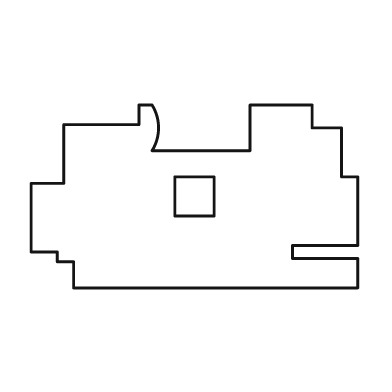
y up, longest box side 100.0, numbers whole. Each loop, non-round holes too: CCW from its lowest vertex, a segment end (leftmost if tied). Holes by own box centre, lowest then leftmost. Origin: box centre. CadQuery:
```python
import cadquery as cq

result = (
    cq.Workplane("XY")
    .moveTo(-37.0, -28.0)
    .lineTo(50.0, -28.0)
    .lineTo(50.0, -19.0)
    .lineTo(30.0, -19.0)
    .lineTo(30.0, -15.0)
    .lineTo(50.0, -15.0)
    .lineTo(50.0, 6.0)
    .lineTo(45.0, 6.0)
    .lineTo(45.0, 21.0)
    .lineTo(36.0, 21.0)
    .lineTo(36.0, 28.0)
    .lineTo(17.0, 28.0)
    .lineTo(17.0, 14.0)
    .lineTo(-13.0, 14.0)
    .threePointArc((-11.0, 21.0), (-13.0, 28.0))
    .lineTo(-17.0, 28.0)
    .lineTo(-17.0, 22.0)
    .lineTo(-40.0, 22.0)
    .lineTo(-40.0, 4.0)
    .lineTo(-50.0, 4.0)
    .lineTo(-50.0, -17.0)
    .lineTo(-42.0, -17.0)
    .lineTo(-42.0, -20.0)
    .lineTo(-37.0, -20.0)
    .close()
    .moveTo(-6.0, -6.0)
    .lineTo(6.0, -6.0)
    .lineTo(6.0, 6.0)
    .lineTo(-6.0, 6.0)
    .close()
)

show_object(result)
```